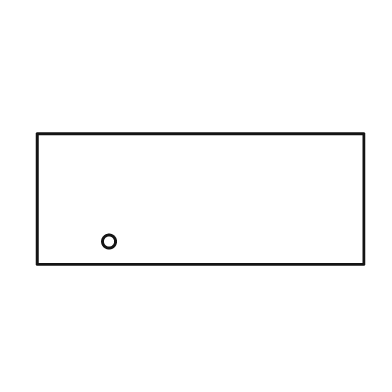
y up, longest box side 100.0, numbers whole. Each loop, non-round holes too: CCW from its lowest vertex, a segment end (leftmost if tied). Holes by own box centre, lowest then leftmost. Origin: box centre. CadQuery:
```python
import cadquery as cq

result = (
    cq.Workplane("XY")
    .moveTo(-50.0, -20.0)
    .lineTo(50.0, -20.0)
    .lineTo(50.0, 20.0)
    .lineTo(-50.0, 20.0)
    .close()
    .moveTo(-28.0, -13.0)
    .circle(2.0)
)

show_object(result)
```